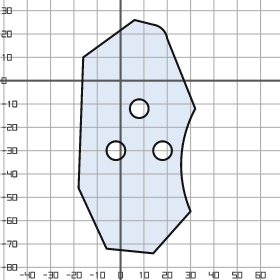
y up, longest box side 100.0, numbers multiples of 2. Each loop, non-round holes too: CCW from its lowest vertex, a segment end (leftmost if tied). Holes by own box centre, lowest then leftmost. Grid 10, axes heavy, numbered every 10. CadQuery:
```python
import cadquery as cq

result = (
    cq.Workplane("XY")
    .moveTo(14.0, -74.0)
    .lineTo(30.0, -56.0)
    .threePointArc((26.0, -34.0), (32.0, -12.0))
    .lineTo(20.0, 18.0)
    .threePointArc((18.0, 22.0), (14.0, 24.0))
    .lineTo(6.0, 26.0)
    .lineTo(-16.0, 10.0)
    .lineTo(-18.0, -46.0)
    .lineTo(-6.0, -72.0)
    .close()
    .moveTo(-2.0, -30.0)
    .circle(4.0)
    .moveTo(18.0, -30.0)
    .circle(4.0)
    .moveTo(8.0, -12.0)
    .circle(4.0)
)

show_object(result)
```